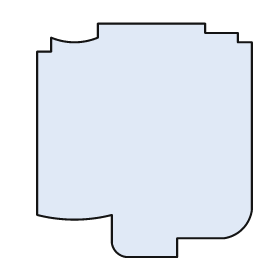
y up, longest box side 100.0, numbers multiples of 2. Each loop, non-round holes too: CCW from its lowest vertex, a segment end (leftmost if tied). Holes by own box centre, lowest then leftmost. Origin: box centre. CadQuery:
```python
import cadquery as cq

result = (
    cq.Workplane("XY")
    .moveTo(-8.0, -50.0)
    .lineTo(14.0, -50.0)
    .lineTo(14.0, -42.0)
    .lineTo(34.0, -42.0)
    .threePointArc((42.0, -38.0), (46.0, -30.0))
    .lineTo(46.0, 42.0)
    .lineTo(40.0, 42.0)
    .lineTo(40.0, 46.0)
    .lineTo(26.0, 46.0)
    .lineTo(26.0, 50.0)
    .lineTo(-20.0, 50.0)
    .lineTo(-20.0, 44.0)
    .threePointArc((-30.0, 42.0), (-40.0, 44.0))
    .lineTo(-40.0, 38.0)
    .lineTo(-46.0, 38.0)
    .lineTo(-46.0, -32.0)
    .threePointArc((-30.0, -34.0), (-14.0, -32.0))
    .lineTo(-14.0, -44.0)
    .threePointArc((-12.0, -48.0), (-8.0, -50.0))
    .close()
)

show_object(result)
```